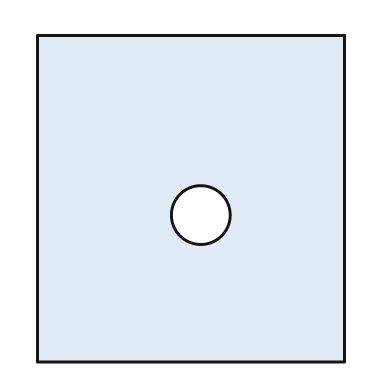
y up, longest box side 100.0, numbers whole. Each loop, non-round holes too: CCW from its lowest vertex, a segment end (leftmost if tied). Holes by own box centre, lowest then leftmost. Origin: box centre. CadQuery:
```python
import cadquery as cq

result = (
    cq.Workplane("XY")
    .moveTo(-47.0, -50.0)
    .lineTo(47.0, -50.0)
    .lineTo(47.0, 50.0)
    .lineTo(-47.0, 50.0)
    .close()
    .moveTo(3.0, -5.0)
    .circle(9.0)
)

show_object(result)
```